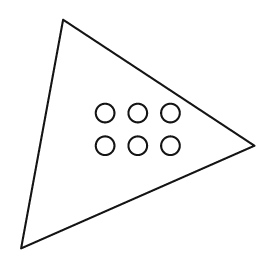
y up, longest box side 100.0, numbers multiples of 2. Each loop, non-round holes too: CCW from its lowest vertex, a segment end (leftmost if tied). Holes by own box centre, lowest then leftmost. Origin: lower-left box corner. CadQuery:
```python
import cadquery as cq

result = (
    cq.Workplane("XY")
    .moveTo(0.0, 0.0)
    .lineTo(100.0, 44.0)
    .lineTo(18.0, 98.0)
    .close()
    .moveTo(36.0, 44.0)
    .circle(4.0)
    .moveTo(50.0, 44.0)
    .circle(4.0)
    .moveTo(64.0, 44.0)
    .circle(4.0)
    .moveTo(36.0, 58.0)
    .circle(4.0)
    .moveTo(50.0, 58.0)
    .circle(4.0)
    .moveTo(64.0, 58.0)
    .circle(4.0)
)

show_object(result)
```